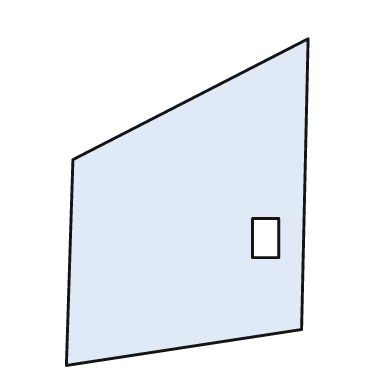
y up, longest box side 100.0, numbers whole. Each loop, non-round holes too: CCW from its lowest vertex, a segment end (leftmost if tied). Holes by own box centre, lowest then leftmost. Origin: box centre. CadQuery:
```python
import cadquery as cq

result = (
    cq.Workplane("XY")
    .moveTo(-37.0, -50.0)
    .lineTo(35.0, -39.0)
    .lineTo(37.0, 50.0)
    .lineTo(-35.0, 13.0)
    .close()
    .moveTo(20.0, -17.0)
    .lineTo(28.0, -17.0)
    .lineTo(28.0, -5.0)
    .lineTo(20.0, -5.0)
    .close()
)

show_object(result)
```